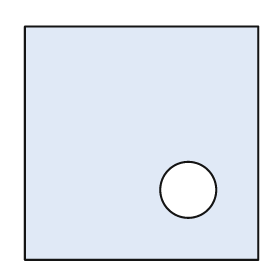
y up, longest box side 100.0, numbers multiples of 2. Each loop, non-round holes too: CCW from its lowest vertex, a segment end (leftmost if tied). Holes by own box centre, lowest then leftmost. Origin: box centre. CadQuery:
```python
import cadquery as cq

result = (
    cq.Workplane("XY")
    .moveTo(-50.0, -50.0)
    .lineTo(50.0, -50.0)
    .lineTo(50.0, 50.0)
    .lineTo(-50.0, 50.0)
    .close()
    .moveTo(20.0, -20.0)
    .circle(12.0)
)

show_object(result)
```